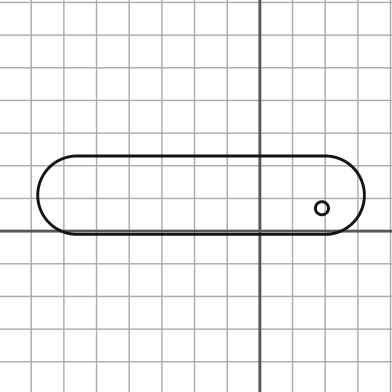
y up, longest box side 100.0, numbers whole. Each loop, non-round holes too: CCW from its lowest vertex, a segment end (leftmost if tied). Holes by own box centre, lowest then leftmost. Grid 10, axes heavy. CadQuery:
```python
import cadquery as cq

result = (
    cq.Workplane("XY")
    .moveTo(-56.0, -1.0)
    .lineTo(20.0, -1.0)
    .threePointArc((32.0, 11.0), (20.0, 23.0))
    .lineTo(-56.0, 23.0)
    .threePointArc((-68.0, 11.0), (-56.0, -1.0))
    .close()
    .moveTo(19.0, 7.0)
    .circle(2.0)
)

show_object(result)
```